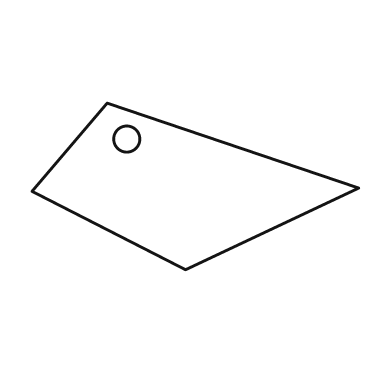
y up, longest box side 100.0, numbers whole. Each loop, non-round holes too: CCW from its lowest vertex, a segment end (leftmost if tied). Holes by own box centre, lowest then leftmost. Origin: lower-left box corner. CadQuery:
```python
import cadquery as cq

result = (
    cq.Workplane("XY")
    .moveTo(47.0, 0.0)
    .lineTo(100.0, 25.0)
    .lineTo(23.0, 51.0)
    .lineTo(0.0, 24.0)
    .close()
    .moveTo(29.0, 40.0)
    .circle(4.0)
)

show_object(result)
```